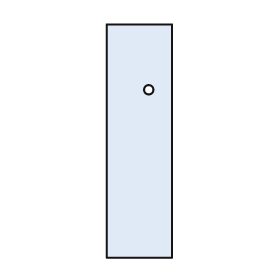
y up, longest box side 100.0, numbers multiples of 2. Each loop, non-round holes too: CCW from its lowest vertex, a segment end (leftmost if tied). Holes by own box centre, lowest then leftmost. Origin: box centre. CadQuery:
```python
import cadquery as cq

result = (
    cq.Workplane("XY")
    .moveTo(-14.0, -50.0)
    .lineTo(14.0, -50.0)
    .lineTo(14.0, 50.0)
    .lineTo(-14.0, 50.0)
    .close()
    .moveTo(4.0, 22.0)
    .circle(2.0)
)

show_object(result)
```